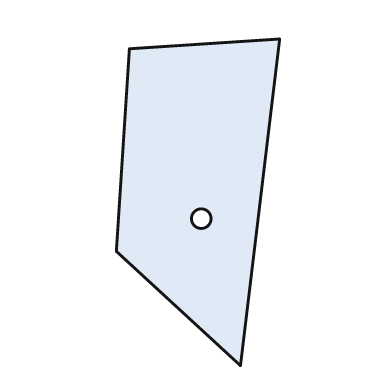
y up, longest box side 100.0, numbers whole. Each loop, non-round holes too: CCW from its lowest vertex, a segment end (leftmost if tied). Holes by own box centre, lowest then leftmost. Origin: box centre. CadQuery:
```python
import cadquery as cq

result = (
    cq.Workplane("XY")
    .moveTo(13.0, -50.0)
    .lineTo(25.0, 50.0)
    .lineTo(-21.0, 47.0)
    .lineTo(-25.0, -15.0)
    .close()
    .moveTo(1.0, -5.0)
    .circle(3.0)
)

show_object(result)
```